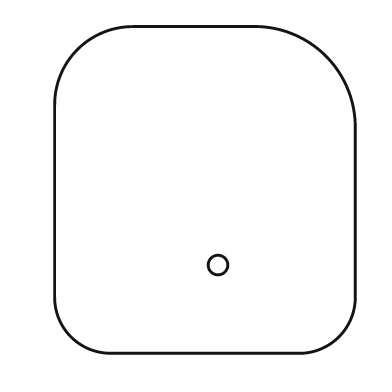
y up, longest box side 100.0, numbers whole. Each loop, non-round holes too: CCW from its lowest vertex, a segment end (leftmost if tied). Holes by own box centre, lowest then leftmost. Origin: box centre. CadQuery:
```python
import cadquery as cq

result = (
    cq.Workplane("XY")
    .moveTo(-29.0, -50.0)
    .lineTo(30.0, -50.0)
    .threePointArc((41.0, -45.0), (46.0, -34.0))
    .lineTo(46.0, 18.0)
    .threePointArc((37.0, 41.0), (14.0, 50.0))
    .lineTo(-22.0, 50.0)
    .threePointArc((-39.0, 43.0), (-46.0, 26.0))
    .lineTo(-46.0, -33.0)
    .threePointArc((-41.0, -45.0), (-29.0, -50.0))
    .close()
    .moveTo(4.0, -23.0)
    .circle(3.0)
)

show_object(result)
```